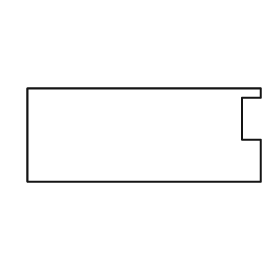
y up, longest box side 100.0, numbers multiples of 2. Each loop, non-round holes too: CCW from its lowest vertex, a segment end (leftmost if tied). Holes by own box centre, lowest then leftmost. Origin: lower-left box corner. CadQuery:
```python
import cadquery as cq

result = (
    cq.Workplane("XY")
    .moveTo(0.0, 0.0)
    .lineTo(100.0, 0.0)
    .lineTo(100.0, 18.0)
    .lineTo(92.0, 18.0)
    .lineTo(92.0, 36.0)
    .lineTo(100.0, 36.0)
    .lineTo(100.0, 40.0)
    .lineTo(0.0, 40.0)
    .close()
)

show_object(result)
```